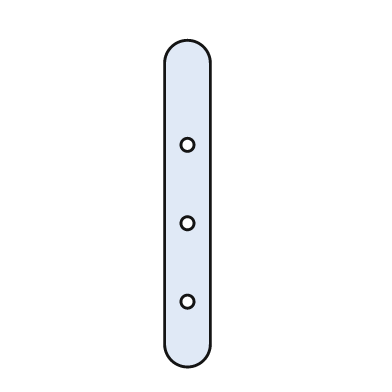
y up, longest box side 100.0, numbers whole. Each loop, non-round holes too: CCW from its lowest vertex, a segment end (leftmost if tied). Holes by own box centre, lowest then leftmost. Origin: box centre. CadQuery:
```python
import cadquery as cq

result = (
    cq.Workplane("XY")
    .moveTo(-7.0, -43.0)
    .threePointArc((0.0, -50.0), (7.0, -43.0))
    .lineTo(7.0, 43.0)
    .threePointArc((0.0, 50.0), (-7.0, 43.0))
    .close()
    .moveTo(0.0, -30.0)
    .circle(2.0)
    .moveTo(0.0, -6.0)
    .circle(2.0)
    .moveTo(0.0, 18.0)
    .circle(2.0)
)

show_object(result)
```